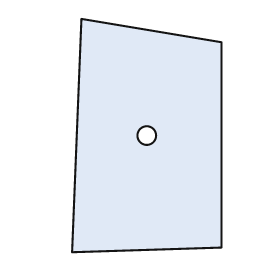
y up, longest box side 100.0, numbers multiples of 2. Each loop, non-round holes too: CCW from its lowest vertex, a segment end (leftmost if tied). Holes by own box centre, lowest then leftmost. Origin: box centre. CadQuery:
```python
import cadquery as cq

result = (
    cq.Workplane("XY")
    .moveTo(-32.0, -50.0)
    .lineTo(32.0, -48.0)
    .lineTo(32.0, 40.0)
    .lineTo(-28.0, 50.0)
    .close()
    .moveTo(0.0, 0.0)
    .circle(4.0)
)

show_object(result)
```